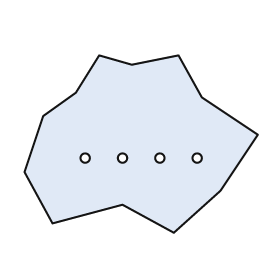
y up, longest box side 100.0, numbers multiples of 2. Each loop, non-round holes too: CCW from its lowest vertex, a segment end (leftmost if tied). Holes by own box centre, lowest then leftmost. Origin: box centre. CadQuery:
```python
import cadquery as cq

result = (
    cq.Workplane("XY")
    .moveTo(14.0, -38.0)
    .lineTo(34.0, -20.0)
    .lineTo(50.0, 4.0)
    .lineTo(26.0, 20.0)
    .lineTo(16.0, 38.0)
    .lineTo(-4.0, 34.0)
    .lineTo(-18.0, 38.0)
    .lineTo(-28.0, 22.0)
    .lineTo(-42.0, 12.0)
    .lineTo(-50.0, -12.0)
    .lineTo(-38.0, -34.0)
    .lineTo(-8.0, -26.0)
    .close()
    .moveTo(-24.0, -6.0)
    .circle(2.0)
    .moveTo(-8.0, -6.0)
    .circle(2.0)
    .moveTo(8.0, -6.0)
    .circle(2.0)
    .moveTo(24.0, -6.0)
    .circle(2.0)
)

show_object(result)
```